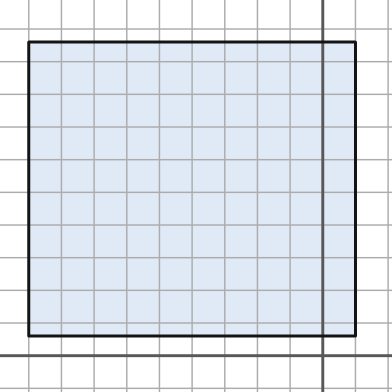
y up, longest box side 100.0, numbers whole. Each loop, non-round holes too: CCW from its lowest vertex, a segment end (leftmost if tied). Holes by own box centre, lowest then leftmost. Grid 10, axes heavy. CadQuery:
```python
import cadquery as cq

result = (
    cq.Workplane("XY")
    .moveTo(-90.0, 6.0)
    .lineTo(10.0, 6.0)
    .lineTo(10.0, 96.0)
    .lineTo(-90.0, 96.0)
    .close()
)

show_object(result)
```